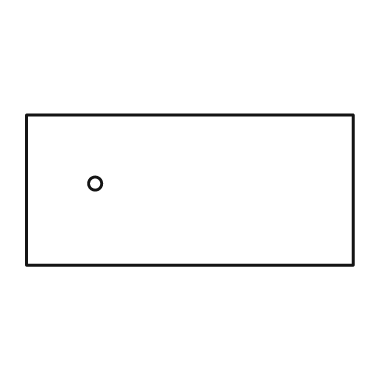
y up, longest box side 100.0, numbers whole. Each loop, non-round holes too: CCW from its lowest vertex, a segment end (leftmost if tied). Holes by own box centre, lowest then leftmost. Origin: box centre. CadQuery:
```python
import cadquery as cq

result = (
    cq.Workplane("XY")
    .moveTo(-50.0, -23.0)
    .lineTo(50.0, -23.0)
    .lineTo(50.0, 23.0)
    .lineTo(-50.0, 23.0)
    .close()
    .moveTo(-29.0, 2.0)
    .circle(2.0)
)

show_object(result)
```